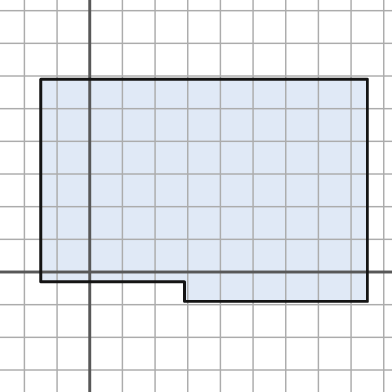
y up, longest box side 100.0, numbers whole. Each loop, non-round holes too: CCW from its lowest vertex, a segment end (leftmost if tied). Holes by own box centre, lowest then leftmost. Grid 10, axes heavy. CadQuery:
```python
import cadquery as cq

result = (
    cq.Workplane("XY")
    .moveTo(29.0, -9.0)
    .lineTo(85.0, -9.0)
    .lineTo(85.0, 59.0)
    .lineTo(-15.0, 59.0)
    .lineTo(-15.0, -3.0)
    .lineTo(29.0, -3.0)
    .close()
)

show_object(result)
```